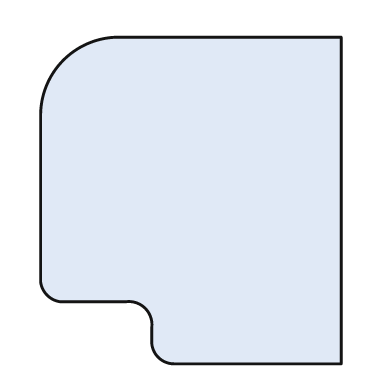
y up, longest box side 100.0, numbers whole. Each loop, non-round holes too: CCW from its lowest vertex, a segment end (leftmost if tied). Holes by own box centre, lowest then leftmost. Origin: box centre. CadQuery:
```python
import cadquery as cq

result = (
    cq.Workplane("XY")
    .moveTo(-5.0, -50.0)
    .lineTo(46.0, -50.0)
    .lineTo(46.0, 50.0)
    .lineTo(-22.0, 50.0)
    .threePointArc((-39.0, 43.0), (-46.0, 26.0))
    .lineTo(-46.0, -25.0)
    .threePointArc((-44.0, -29.0), (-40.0, -31.0))
    .lineTo(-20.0, -31.0)
    .threePointArc((-14.0, -33.0), (-12.0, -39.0))
    .lineTo(-12.0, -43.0)
    .threePointArc((-10.0, -48.0), (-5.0, -50.0))
    .close()
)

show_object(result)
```